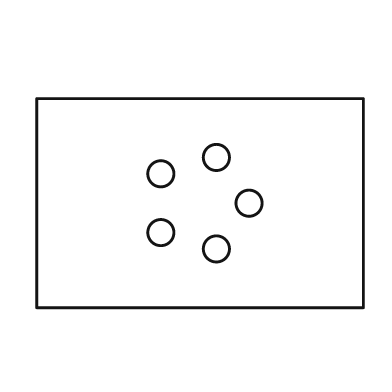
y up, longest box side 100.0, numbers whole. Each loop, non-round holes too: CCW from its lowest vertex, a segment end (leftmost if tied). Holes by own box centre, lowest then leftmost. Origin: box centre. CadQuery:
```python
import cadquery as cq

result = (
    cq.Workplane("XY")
    .moveTo(-50.0, -32.0)
    .lineTo(50.0, -32.0)
    .lineTo(50.0, 32.0)
    .lineTo(-50.0, 32.0)
    .close()
    .moveTo(5.0, -14.0)
    .circle(4.0)
    .moveTo(-12.0, -9.0)
    .circle(4.0)
    .moveTo(15.0, 0.0)
    .circle(4.0)
    .moveTo(-12.0, 9.0)
    .circle(4.0)
    .moveTo(5.0, 14.0)
    .circle(4.0)
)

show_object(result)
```